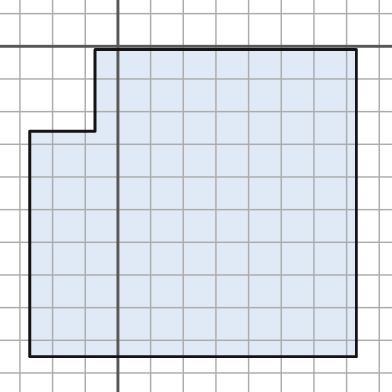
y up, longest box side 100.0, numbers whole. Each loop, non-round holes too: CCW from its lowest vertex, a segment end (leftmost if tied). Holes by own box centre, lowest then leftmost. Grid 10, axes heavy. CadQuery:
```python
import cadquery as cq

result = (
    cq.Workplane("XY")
    .moveTo(-27.0, -95.0)
    .lineTo(73.0, -95.0)
    .lineTo(73.0, -1.0)
    .lineTo(-7.0, -1.0)
    .lineTo(-7.0, -26.0)
    .lineTo(-27.0, -26.0)
    .close()
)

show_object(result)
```